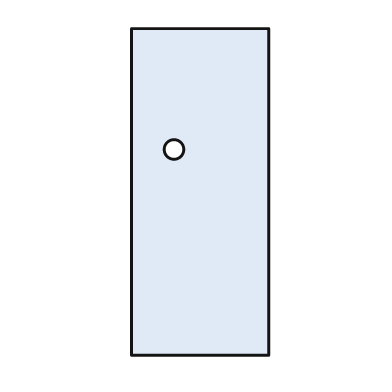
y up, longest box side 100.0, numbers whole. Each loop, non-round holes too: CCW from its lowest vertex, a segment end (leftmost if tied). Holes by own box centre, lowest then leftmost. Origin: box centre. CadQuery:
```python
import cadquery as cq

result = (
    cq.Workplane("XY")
    .moveTo(-21.0, -50.0)
    .lineTo(21.0, -50.0)
    .lineTo(21.0, 50.0)
    .lineTo(-21.0, 50.0)
    .close()
    .moveTo(-8.0, 13.0)
    .circle(3.0)
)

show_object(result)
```